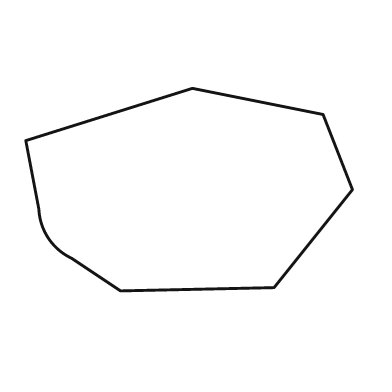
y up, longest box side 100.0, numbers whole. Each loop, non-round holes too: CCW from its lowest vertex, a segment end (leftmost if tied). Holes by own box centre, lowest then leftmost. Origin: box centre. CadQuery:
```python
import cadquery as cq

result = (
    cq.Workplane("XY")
    .moveTo(-21.0, -31.0)
    .lineTo(26.0, -30.0)
    .lineTo(50.0, 0.0)
    .lineTo(41.0, 23.0)
    .lineTo(1.0, 31.0)
    .lineTo(-50.0, 15.0)
    .lineTo(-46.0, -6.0)
    .threePointArc((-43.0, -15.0), (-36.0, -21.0))
    .close()
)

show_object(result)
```